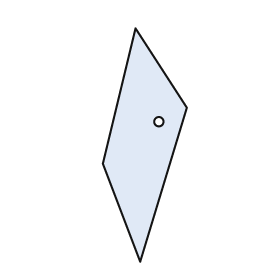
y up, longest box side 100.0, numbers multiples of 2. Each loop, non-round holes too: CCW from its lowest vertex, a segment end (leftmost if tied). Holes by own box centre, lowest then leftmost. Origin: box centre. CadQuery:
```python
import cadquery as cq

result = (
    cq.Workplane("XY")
    .moveTo(-2.0, -50.0)
    .lineTo(18.0, 16.0)
    .lineTo(-4.0, 50.0)
    .lineTo(-18.0, -8.0)
    .close()
    .moveTo(6.0, 10.0)
    .circle(2.0)
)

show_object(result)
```